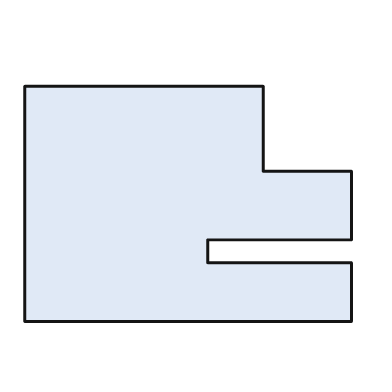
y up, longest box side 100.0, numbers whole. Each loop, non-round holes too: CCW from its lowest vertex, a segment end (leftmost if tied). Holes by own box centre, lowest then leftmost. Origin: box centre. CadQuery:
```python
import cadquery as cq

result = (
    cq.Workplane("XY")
    .moveTo(-50.0, -36.0)
    .lineTo(50.0, -36.0)
    .lineTo(50.0, -18.0)
    .lineTo(6.0, -18.0)
    .lineTo(6.0, -11.0)
    .lineTo(50.0, -11.0)
    .lineTo(50.0, 10.0)
    .lineTo(23.0, 10.0)
    .lineTo(23.0, 36.0)
    .lineTo(-50.0, 36.0)
    .close()
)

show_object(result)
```